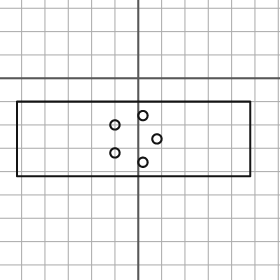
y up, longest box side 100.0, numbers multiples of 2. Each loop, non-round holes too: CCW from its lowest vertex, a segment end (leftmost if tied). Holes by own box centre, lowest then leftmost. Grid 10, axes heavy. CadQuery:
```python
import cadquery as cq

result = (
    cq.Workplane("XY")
    .moveTo(-52.0, -42.0)
    .lineTo(48.0, -42.0)
    .lineTo(48.0, -10.0)
    .lineTo(-52.0, -10.0)
    .close()
    .moveTo(2.0, -36.0)
    .circle(2.0)
    .moveTo(-10.0, -32.0)
    .circle(2.0)
    .moveTo(8.0, -26.0)
    .circle(2.0)
    .moveTo(-10.0, -20.0)
    .circle(2.0)
    .moveTo(2.0, -16.0)
    .circle(2.0)
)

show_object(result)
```